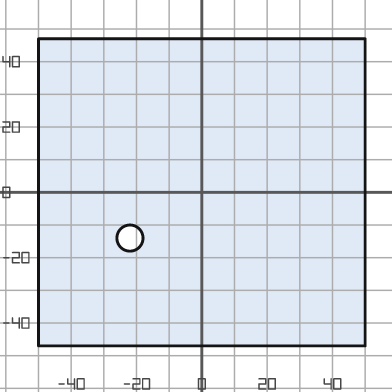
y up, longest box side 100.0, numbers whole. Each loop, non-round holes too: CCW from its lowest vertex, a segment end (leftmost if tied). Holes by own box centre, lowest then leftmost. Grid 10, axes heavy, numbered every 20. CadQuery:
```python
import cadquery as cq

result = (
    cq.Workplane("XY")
    .moveTo(-50.0, -47.0)
    .lineTo(50.0, -47.0)
    .lineTo(50.0, 47.0)
    .lineTo(-50.0, 47.0)
    .close()
    .moveTo(-22.0, -14.0)
    .circle(4.0)
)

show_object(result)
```